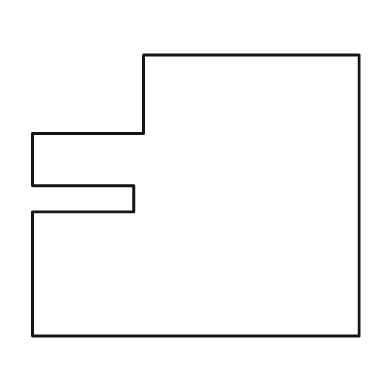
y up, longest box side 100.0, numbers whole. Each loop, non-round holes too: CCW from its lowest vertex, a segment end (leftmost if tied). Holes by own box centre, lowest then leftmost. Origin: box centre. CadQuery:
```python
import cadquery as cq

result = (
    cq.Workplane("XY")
    .moveTo(-50.0, -43.0)
    .lineTo(50.0, -43.0)
    .lineTo(50.0, 43.0)
    .lineTo(-16.0, 43.0)
    .lineTo(-16.0, 19.0)
    .lineTo(-50.0, 19.0)
    .lineTo(-50.0, 3.0)
    .lineTo(-19.0, 3.0)
    .lineTo(-19.0, -5.0)
    .lineTo(-50.0, -5.0)
    .close()
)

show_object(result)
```